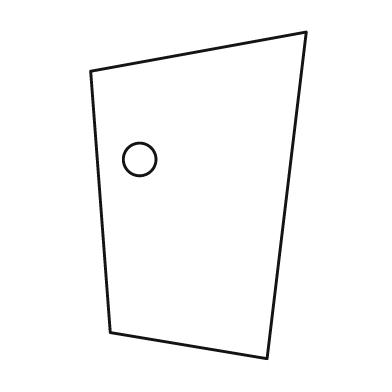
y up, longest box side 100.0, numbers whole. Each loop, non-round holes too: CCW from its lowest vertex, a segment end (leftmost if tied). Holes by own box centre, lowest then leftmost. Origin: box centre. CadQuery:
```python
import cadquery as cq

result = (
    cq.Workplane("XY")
    .moveTo(21.0, -50.0)
    .lineTo(33.0, 50.0)
    .lineTo(-33.0, 38.0)
    .lineTo(-27.0, -42.0)
    .close()
    .moveTo(-18.0, 11.0)
    .circle(5.0)
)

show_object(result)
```